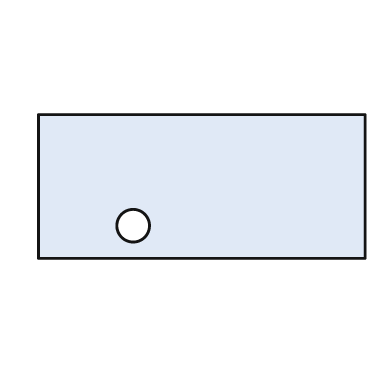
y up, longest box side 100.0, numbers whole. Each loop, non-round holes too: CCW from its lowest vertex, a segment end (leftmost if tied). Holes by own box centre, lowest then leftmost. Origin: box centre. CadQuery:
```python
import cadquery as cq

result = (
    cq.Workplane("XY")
    .moveTo(-50.0, -22.0)
    .lineTo(50.0, -22.0)
    .lineTo(50.0, 22.0)
    .lineTo(-50.0, 22.0)
    .close()
    .moveTo(-21.0, -12.0)
    .circle(5.0)
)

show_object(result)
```